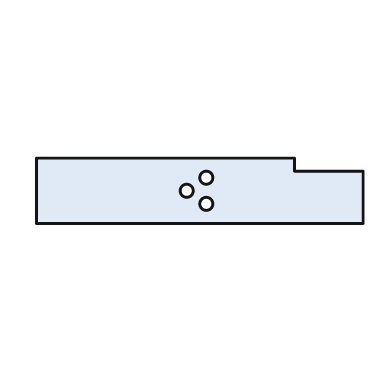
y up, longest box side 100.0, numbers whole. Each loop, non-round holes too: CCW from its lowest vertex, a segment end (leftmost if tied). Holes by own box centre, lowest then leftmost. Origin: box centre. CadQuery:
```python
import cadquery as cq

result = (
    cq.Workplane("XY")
    .moveTo(-50.0, -10.0)
    .lineTo(50.0, -10.0)
    .lineTo(50.0, 6.0)
    .lineTo(29.0, 6.0)
    .lineTo(29.0, 10.0)
    .lineTo(-50.0, 10.0)
    .close()
    .moveTo(2.0, -4.0)
    .circle(2.0)
    .moveTo(-4.0, 0.0)
    .circle(2.0)
    .moveTo(2.0, 4.0)
    .circle(2.0)
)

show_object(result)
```